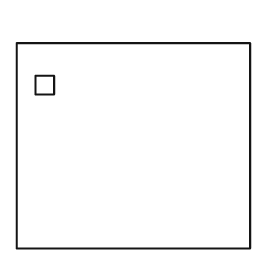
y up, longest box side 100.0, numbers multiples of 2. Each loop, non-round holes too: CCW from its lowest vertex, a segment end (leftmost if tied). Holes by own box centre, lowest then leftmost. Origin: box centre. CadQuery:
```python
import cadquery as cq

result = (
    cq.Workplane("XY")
    .moveTo(-50.0, -44.0)
    .lineTo(50.0, -44.0)
    .lineTo(50.0, 44.0)
    .lineTo(-50.0, 44.0)
    .close()
    .moveTo(-42.0, 22.0)
    .lineTo(-34.0, 22.0)
    .lineTo(-34.0, 30.0)
    .lineTo(-42.0, 30.0)
    .close()
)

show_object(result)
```